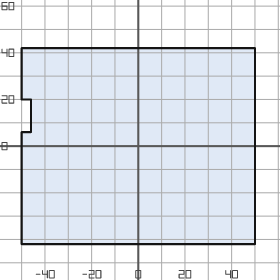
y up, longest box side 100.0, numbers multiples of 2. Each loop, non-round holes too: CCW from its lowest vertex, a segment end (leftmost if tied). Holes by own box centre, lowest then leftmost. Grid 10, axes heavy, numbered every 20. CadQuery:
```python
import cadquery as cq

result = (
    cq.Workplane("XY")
    .moveTo(-50.0, -42.0)
    .lineTo(50.0, -42.0)
    .lineTo(50.0, 42.0)
    .lineTo(-50.0, 42.0)
    .lineTo(-50.0, 20.0)
    .lineTo(-46.0, 20.0)
    .lineTo(-46.0, 6.0)
    .lineTo(-50.0, 6.0)
    .close()
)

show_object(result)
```